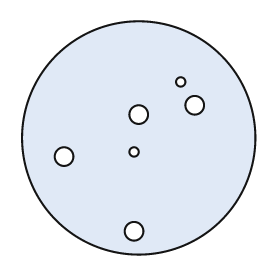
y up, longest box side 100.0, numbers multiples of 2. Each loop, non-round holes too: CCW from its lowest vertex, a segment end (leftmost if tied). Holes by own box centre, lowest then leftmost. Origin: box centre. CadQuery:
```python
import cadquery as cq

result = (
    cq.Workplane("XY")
    .moveTo(0.0, 0.0)
    .circle(50.0)
    .moveTo(-2.0, -40.0)
    .circle(4.0)
    .moveTo(-32.0, -8.0)
    .circle(4.0)
    .moveTo(-2.0, -6.0)
    .circle(2.0)
    .moveTo(0.0, 10.0)
    .circle(4.0)
    .moveTo(24.0, 14.0)
    .circle(4.0)
    .moveTo(18.0, 24.0)
    .circle(2.0)
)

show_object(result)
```